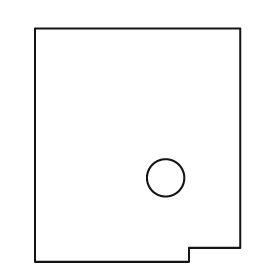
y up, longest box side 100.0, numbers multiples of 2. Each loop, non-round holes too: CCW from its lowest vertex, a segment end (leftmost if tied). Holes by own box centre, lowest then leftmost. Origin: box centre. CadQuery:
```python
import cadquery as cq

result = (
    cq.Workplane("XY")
    .moveTo(-44.0, -50.0)
    .lineTo(22.0, -50.0)
    .lineTo(22.0, -44.0)
    .lineTo(44.0, -44.0)
    .lineTo(44.0, 50.0)
    .lineTo(-44.0, 50.0)
    .close()
    .moveTo(12.0, -14.0)
    .circle(8.0)
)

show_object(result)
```